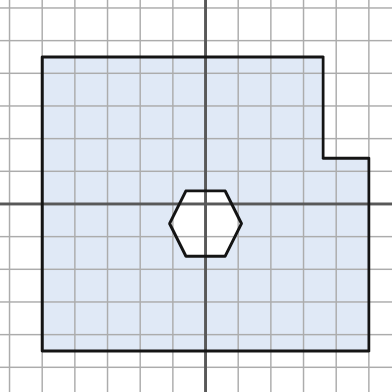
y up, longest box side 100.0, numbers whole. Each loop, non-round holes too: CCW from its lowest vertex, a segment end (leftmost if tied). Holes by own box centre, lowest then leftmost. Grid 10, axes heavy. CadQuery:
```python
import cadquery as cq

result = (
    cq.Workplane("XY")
    .moveTo(-50.0, -45.0)
    .lineTo(50.0, -45.0)
    .lineTo(50.0, 14.0)
    .lineTo(36.0, 14.0)
    .lineTo(36.0, 45.0)
    .lineTo(-50.0, 45.0)
    .close()
    .moveTo(-6.0, -16.0)
    .lineTo(6.0, -16.0)
    .lineTo(11.0, -6.0)
    .lineTo(6.0, 4.0)
    .lineTo(-6.0, 4.0)
    .lineTo(-11.0, -6.0)
    .close()
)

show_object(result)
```